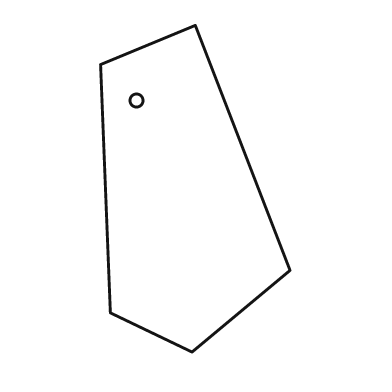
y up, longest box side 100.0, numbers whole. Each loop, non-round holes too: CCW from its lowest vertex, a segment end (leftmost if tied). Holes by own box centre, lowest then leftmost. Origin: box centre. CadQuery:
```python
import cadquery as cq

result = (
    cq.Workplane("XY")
    .moveTo(-1.0, -50.0)
    .lineTo(29.0, -25.0)
    .lineTo(0.0, 50.0)
    .lineTo(-29.0, 38.0)
    .lineTo(-26.0, -38.0)
    .close()
    .moveTo(-18.0, 27.0)
    .circle(2.0)
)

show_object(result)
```